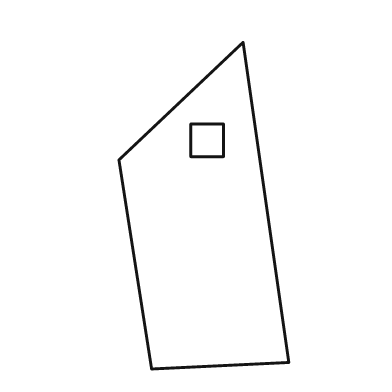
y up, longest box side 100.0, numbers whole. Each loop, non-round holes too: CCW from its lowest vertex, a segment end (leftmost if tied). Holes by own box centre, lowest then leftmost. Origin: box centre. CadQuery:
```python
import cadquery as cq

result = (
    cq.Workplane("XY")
    .moveTo(-16.0, -50.0)
    .lineTo(26.0, -48.0)
    .lineTo(12.0, 50.0)
    .lineTo(-26.0, 14.0)
    .close()
    .moveTo(-4.0, 15.0)
    .lineTo(6.0, 15.0)
    .lineTo(6.0, 25.0)
    .lineTo(-4.0, 25.0)
    .close()
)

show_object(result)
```